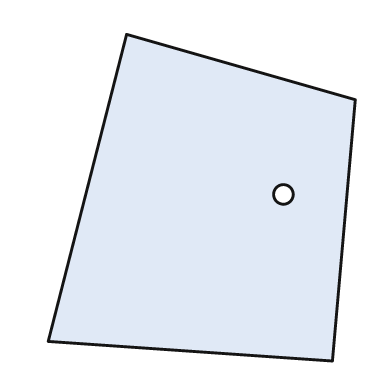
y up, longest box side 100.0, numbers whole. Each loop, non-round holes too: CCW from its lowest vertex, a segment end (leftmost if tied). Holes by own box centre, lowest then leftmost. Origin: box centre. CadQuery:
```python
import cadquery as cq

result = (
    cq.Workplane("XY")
    .moveTo(40.0, -50.0)
    .lineTo(47.0, 30.0)
    .lineTo(-23.0, 50.0)
    .lineTo(-47.0, -44.0)
    .close()
    .moveTo(25.0, 1.0)
    .circle(3.0)
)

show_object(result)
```